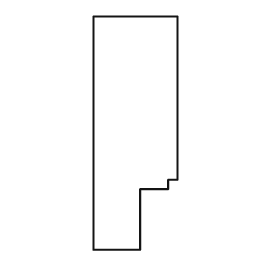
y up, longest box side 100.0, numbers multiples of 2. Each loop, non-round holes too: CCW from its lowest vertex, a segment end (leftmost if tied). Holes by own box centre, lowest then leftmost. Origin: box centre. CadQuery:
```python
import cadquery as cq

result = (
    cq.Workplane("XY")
    .moveTo(-18.0, -50.0)
    .lineTo(2.0, -50.0)
    .lineTo(2.0, -24.0)
    .lineTo(14.0, -24.0)
    .lineTo(14.0, -20.0)
    .lineTo(18.0, -20.0)
    .lineTo(18.0, 50.0)
    .lineTo(-18.0, 50.0)
    .close()
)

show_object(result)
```